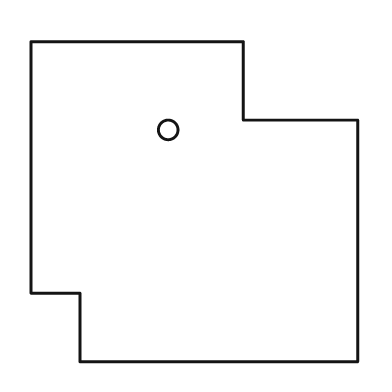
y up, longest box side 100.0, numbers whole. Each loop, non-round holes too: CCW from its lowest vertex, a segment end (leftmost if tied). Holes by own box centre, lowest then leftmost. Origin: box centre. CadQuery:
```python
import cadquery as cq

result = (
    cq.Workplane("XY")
    .moveTo(-35.0, -49.0)
    .lineTo(50.0, -49.0)
    .lineTo(50.0, 25.0)
    .lineTo(15.0, 25.0)
    .lineTo(15.0, 49.0)
    .lineTo(-50.0, 49.0)
    .lineTo(-50.0, -28.0)
    .lineTo(-35.0, -28.0)
    .close()
    .moveTo(-8.0, 22.0)
    .circle(3.0)
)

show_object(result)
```